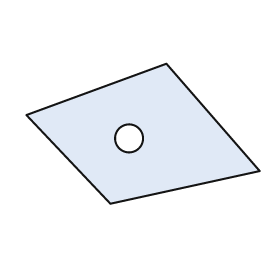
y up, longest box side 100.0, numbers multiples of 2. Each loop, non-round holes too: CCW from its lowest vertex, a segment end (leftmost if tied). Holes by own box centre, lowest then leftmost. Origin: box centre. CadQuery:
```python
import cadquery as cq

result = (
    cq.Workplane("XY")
    .moveTo(-14.0, -30.0)
    .lineTo(50.0, -16.0)
    .lineTo(10.0, 30.0)
    .lineTo(-50.0, 8.0)
    .close()
    .moveTo(-6.0, -2.0)
    .circle(6.0)
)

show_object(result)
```